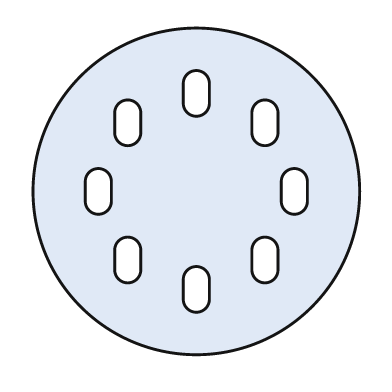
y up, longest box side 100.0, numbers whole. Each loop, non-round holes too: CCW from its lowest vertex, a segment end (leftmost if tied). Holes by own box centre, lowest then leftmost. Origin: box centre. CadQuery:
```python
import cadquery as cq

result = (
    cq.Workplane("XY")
    .moveTo(0.0, 0.0)
    .circle(50.0)
    .moveTo(-4.0, -33.0)
    .threePointArc((0.0, -37.0), (4.0, -33.0))
    .lineTo(4.0, -27.0)
    .threePointArc((0.0, -23.0), (-4.0, -27.0))
    .close()
    .moveTo(-25.0, -24.0)
    .threePointArc((-21.0, -28.0), (-17.0, -24.0))
    .lineTo(-17.0, -18.0)
    .threePointArc((-21.0, -14.0), (-25.0, -18.0))
    .close()
    .moveTo(17.0, -24.0)
    .threePointArc((21.0, -28.0), (25.0, -24.0))
    .lineTo(25.0, -18.0)
    .threePointArc((21.0, -14.0), (17.0, -18.0))
    .close()
    .moveTo(-34.0, -3.0)
    .threePointArc((-30.0, -7.0), (-26.0, -3.0))
    .lineTo(-26.0, 3.0)
    .threePointArc((-30.0, 7.0), (-34.0, 3.0))
    .close()
    .moveTo(26.0, -3.0)
    .threePointArc((30.0, -7.0), (34.0, -3.0))
    .lineTo(34.0, 3.0)
    .threePointArc((30.0, 7.0), (26.0, 3.0))
    .close()
    .moveTo(-25.0, 18.0)
    .threePointArc((-21.0, 14.0), (-17.0, 18.0))
    .lineTo(-17.0, 24.0)
    .threePointArc((-21.0, 28.0), (-25.0, 24.0))
    .close()
    .moveTo(17.0, 18.0)
    .threePointArc((21.0, 14.0), (25.0, 18.0))
    .lineTo(25.0, 24.0)
    .threePointArc((21.0, 28.0), (17.0, 24.0))
    .close()
    .moveTo(-4.0, 27.0)
    .threePointArc((0.0, 23.0), (4.0, 27.0))
    .lineTo(4.0, 33.0)
    .threePointArc((0.0, 37.0), (-4.0, 33.0))
    .close()
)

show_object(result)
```